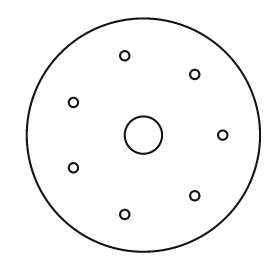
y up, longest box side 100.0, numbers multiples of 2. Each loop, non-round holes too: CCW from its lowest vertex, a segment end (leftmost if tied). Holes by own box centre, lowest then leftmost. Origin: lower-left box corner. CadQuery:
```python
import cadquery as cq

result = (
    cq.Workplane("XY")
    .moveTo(50.0, 50.0)
    .circle(50.0)
    .moveTo(42.0, 16.0)
    .circle(2.0)
    .moveTo(72.0, 24.0)
    .circle(2.0)
    .moveTo(20.0, 36.0)
    .circle(2.0)
    .moveTo(50.0, 50.0)
    .circle(8.0)
    .moveTo(84.0, 50.0)
    .circle(2.0)
    .moveTo(20.0, 64.0)
    .circle(2.0)
    .moveTo(72.0, 76.0)
    .circle(2.0)
    .moveTo(42.0, 84.0)
    .circle(2.0)
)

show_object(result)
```